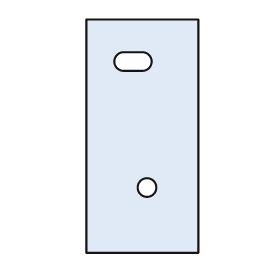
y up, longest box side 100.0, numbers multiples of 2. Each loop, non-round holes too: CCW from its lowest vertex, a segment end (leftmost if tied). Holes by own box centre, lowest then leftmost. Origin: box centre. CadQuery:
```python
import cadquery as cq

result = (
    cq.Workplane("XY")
    .moveTo(-24.0, -50.0)
    .lineTo(24.0, -50.0)
    .lineTo(24.0, 50.0)
    .lineTo(-24.0, 50.0)
    .close()
    .moveTo(2.0, -22.0)
    .circle(4.0)
    .moveTo(-8.0, 28.0)
    .lineTo(0.0, 28.0)
    .threePointArc((4.0, 32.0), (0.0, 36.0))
    .lineTo(-8.0, 36.0)
    .threePointArc((-12.0, 32.0), (-8.0, 28.0))
    .close()
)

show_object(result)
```